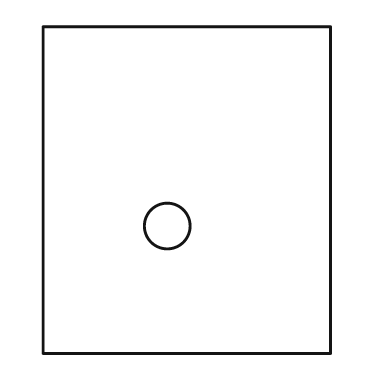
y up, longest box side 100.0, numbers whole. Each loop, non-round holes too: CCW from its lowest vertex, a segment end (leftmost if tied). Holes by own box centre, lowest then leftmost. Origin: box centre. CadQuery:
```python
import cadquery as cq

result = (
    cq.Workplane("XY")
    .moveTo(-44.0, -50.0)
    .lineTo(44.0, -50.0)
    .lineTo(44.0, 50.0)
    .lineTo(-44.0, 50.0)
    .close()
    .moveTo(-6.0, -11.0)
    .circle(7.0)
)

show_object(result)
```